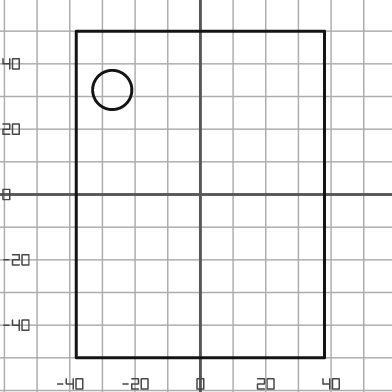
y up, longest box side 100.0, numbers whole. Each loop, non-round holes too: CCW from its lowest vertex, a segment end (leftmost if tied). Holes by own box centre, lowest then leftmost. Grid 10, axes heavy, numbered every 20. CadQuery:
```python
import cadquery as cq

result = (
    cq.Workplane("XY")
    .moveTo(-38.0, -50.0)
    .lineTo(38.0, -50.0)
    .lineTo(38.0, 50.0)
    .lineTo(-38.0, 50.0)
    .close()
    .moveTo(-27.0, 32.0)
    .circle(6.0)
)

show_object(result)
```